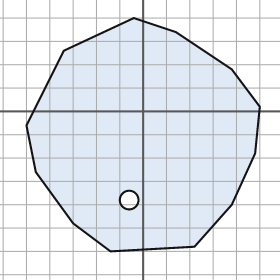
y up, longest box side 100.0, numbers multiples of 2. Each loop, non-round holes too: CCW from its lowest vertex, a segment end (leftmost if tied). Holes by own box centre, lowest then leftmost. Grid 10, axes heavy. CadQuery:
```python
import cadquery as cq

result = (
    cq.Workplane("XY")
    .moveTo(-14.0, -60.0)
    .lineTo(22.0, -58.0)
    .lineTo(38.0, -40.0)
    .lineTo(48.0, -18.0)
    .lineTo(50.0, 2.0)
    .lineTo(38.0, 18.0)
    .lineTo(14.0, 34.0)
    .lineTo(-4.0, 40.0)
    .lineTo(-34.0, 26.0)
    .lineTo(-50.0, -6.0)
    .lineTo(-46.0, -26.0)
    .lineTo(-30.0, -48.0)
    .close()
    .moveTo(-6.0, -38.0)
    .circle(4.0)
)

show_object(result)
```